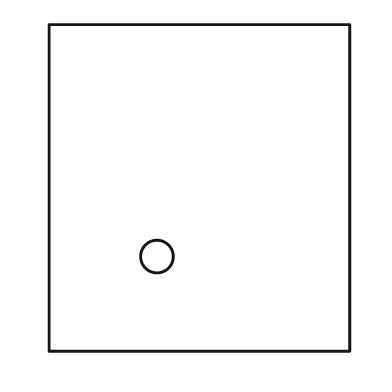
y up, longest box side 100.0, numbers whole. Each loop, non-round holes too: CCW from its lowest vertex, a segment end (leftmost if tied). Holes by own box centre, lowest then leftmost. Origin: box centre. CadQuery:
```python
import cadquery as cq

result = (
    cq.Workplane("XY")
    .moveTo(-46.0, -50.0)
    .lineTo(46.0, -50.0)
    .lineTo(46.0, 50.0)
    .lineTo(-46.0, 50.0)
    .close()
    .moveTo(-13.0, -21.0)
    .circle(5.0)
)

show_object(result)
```